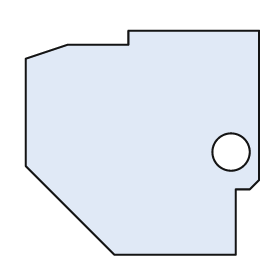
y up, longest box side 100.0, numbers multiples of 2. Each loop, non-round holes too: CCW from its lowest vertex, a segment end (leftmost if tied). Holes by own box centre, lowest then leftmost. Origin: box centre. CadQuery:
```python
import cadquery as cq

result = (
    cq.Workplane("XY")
    .moveTo(-12.0, -48.0)
    .lineTo(40.0, -48.0)
    .lineTo(40.0, -20.0)
    .lineTo(46.0, -20.0)
    .lineTo(50.0, -16.0)
    .lineTo(50.0, 48.0)
    .lineTo(-6.0, 48.0)
    .lineTo(-6.0, 42.0)
    .lineTo(-32.0, 42.0)
    .lineTo(-50.0, 36.0)
    .lineTo(-50.0, -10.0)
    .close()
    .moveTo(38.0, -4.0)
    .circle(8.0)
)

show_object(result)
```